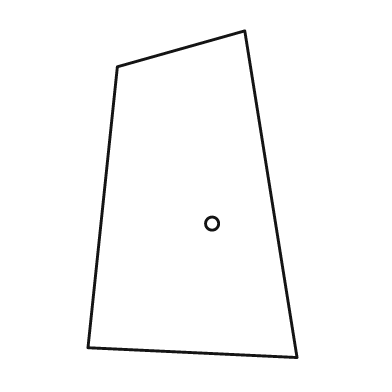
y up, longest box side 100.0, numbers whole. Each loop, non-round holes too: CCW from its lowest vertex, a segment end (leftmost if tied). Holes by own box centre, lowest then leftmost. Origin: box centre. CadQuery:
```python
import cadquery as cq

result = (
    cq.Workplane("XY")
    .moveTo(32.0, -50.0)
    .lineTo(16.0, 50.0)
    .lineTo(-23.0, 39.0)
    .lineTo(-32.0, -47.0)
    .close()
    .moveTo(6.0, -9.0)
    .circle(2.0)
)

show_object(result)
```